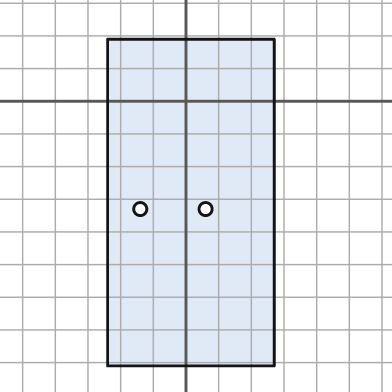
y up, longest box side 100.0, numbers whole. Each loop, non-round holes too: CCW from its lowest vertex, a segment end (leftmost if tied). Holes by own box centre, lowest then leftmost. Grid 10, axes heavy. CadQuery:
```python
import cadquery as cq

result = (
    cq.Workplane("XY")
    .moveTo(-24.0, -81.0)
    .lineTo(27.0, -81.0)
    .lineTo(27.0, 19.0)
    .lineTo(-24.0, 19.0)
    .close()
    .moveTo(-14.0, -33.0)
    .circle(2.0)
    .moveTo(6.0, -33.0)
    .circle(2.0)
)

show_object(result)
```